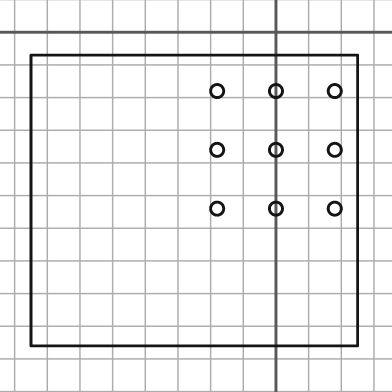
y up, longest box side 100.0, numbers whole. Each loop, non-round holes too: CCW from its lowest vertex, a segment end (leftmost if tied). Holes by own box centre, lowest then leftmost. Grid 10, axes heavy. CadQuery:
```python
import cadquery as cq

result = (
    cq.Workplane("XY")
    .moveTo(-75.0, -96.0)
    .lineTo(25.0, -96.0)
    .lineTo(25.0, -7.0)
    .lineTo(-75.0, -7.0)
    .close()
    .moveTo(-18.0, -54.0)
    .circle(2.0)
    .moveTo(0.0, -54.0)
    .circle(2.0)
    .moveTo(18.0, -54.0)
    .circle(2.0)
    .moveTo(-18.0, -36.0)
    .circle(2.0)
    .moveTo(0.0, -36.0)
    .circle(2.0)
    .moveTo(18.0, -36.0)
    .circle(2.0)
    .moveTo(-18.0, -18.0)
    .circle(2.0)
    .moveTo(0.0, -18.0)
    .circle(2.0)
    .moveTo(18.0, -18.0)
    .circle(2.0)
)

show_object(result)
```